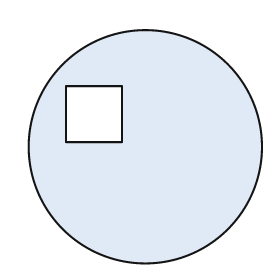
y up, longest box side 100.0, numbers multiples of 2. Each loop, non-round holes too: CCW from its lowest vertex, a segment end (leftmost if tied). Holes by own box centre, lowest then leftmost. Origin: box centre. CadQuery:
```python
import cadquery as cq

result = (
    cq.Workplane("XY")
    .moveTo(0.0, 0.0)
    .circle(50.0)
    .moveTo(-34.0, 2.0)
    .lineTo(-10.0, 2.0)
    .lineTo(-10.0, 26.0)
    .lineTo(-34.0, 26.0)
    .close()
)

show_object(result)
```